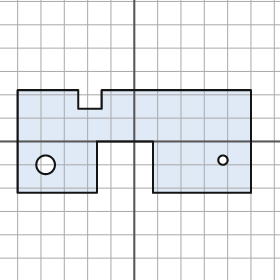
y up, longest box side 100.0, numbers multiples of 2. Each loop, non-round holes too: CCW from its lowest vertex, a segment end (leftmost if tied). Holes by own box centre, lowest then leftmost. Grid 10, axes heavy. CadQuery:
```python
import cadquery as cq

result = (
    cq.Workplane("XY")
    .moveTo(-50.0, -22.0)
    .lineTo(-16.0, -22.0)
    .lineTo(-16.0, 0.0)
    .lineTo(8.0, 0.0)
    .lineTo(8.0, -22.0)
    .lineTo(50.0, -22.0)
    .lineTo(50.0, 22.0)
    .lineTo(-14.0, 22.0)
    .lineTo(-14.0, 14.0)
    .lineTo(-24.0, 14.0)
    .lineTo(-24.0, 22.0)
    .lineTo(-50.0, 22.0)
    .close()
    .moveTo(-38.0, -10.0)
    .circle(4.0)
    .moveTo(38.0, -8.0)
    .circle(2.0)
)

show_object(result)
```